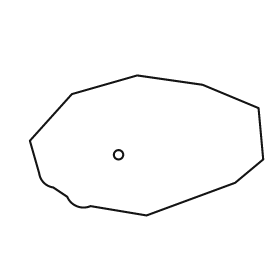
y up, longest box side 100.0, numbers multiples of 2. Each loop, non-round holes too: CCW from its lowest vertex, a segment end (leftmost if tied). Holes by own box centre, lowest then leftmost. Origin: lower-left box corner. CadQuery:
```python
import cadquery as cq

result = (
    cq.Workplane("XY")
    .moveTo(50.0, 0.0)
    .lineTo(88.0, 14.0)
    .lineTo(100.0, 24.0)
    .lineTo(98.0, 46.0)
    .lineTo(74.0, 56.0)
    .lineTo(46.0, 60.0)
    .lineTo(18.0, 52.0)
    .lineTo(0.0, 32.0)
    .lineTo(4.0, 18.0)
    .threePointArc((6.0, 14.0), (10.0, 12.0))
    .lineTo(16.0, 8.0)
    .threePointArc((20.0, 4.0), (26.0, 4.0))
    .close()
    .moveTo(38.0, 26.0)
    .circle(2.0)
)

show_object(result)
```